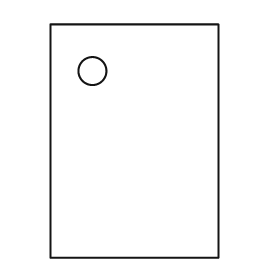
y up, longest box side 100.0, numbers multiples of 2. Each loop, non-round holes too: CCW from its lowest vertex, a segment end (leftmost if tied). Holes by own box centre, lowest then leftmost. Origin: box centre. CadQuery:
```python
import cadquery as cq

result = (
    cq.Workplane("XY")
    .moveTo(-36.0, -50.0)
    .lineTo(36.0, -50.0)
    .lineTo(36.0, 50.0)
    .lineTo(-36.0, 50.0)
    .close()
    .moveTo(-18.0, 30.0)
    .circle(6.0)
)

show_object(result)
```